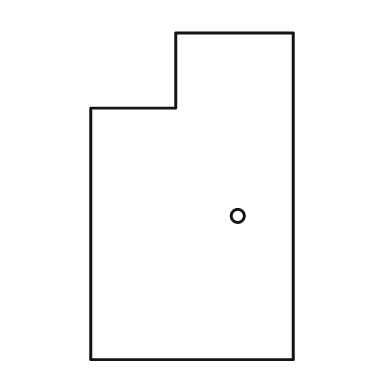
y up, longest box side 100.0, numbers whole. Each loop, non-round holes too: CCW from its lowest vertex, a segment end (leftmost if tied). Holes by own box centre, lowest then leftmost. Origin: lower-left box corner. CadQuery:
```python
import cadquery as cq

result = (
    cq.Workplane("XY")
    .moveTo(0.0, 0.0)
    .lineTo(62.0, 0.0)
    .lineTo(62.0, 100.0)
    .lineTo(26.0, 100.0)
    .lineTo(26.0, 77.0)
    .lineTo(0.0, 77.0)
    .close()
    .moveTo(45.0, 44.0)
    .circle(2.0)
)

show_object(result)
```